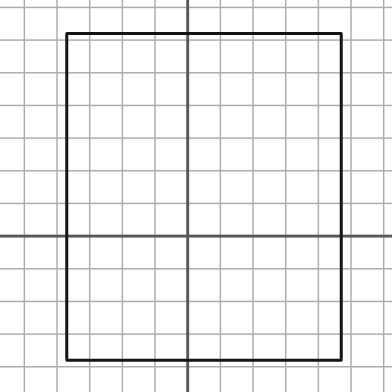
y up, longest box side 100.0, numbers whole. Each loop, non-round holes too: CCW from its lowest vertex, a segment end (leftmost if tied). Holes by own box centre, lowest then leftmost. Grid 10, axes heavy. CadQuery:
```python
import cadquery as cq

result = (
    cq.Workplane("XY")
    .moveTo(-37.0, -38.0)
    .lineTo(47.0, -38.0)
    .lineTo(47.0, 62.0)
    .lineTo(-37.0, 62.0)
    .close()
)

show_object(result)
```